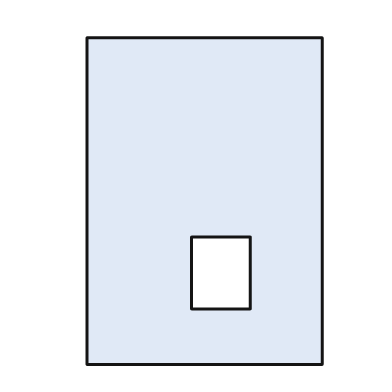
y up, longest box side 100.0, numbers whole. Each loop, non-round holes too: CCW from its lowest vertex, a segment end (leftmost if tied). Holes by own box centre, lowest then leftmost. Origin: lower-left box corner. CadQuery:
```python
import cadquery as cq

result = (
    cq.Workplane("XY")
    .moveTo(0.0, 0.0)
    .lineTo(72.0, 0.0)
    .lineTo(72.0, 100.0)
    .lineTo(0.0, 100.0)
    .close()
    .moveTo(32.0, 17.0)
    .lineTo(50.0, 17.0)
    .lineTo(50.0, 39.0)
    .lineTo(32.0, 39.0)
    .close()
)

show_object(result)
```